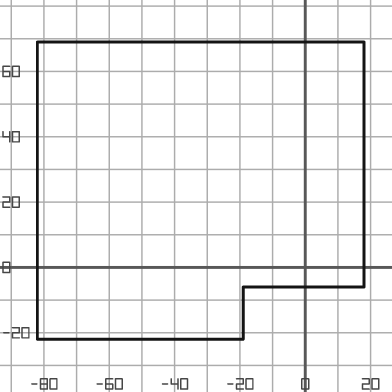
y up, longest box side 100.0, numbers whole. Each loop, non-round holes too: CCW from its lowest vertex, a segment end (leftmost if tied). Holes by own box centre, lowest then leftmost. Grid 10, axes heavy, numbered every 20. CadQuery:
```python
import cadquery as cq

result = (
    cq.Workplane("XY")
    .moveTo(-82.0, -22.0)
    .lineTo(-19.0, -22.0)
    .lineTo(-19.0, -6.0)
    .lineTo(18.0, -6.0)
    .lineTo(18.0, 69.0)
    .lineTo(-82.0, 69.0)
    .close()
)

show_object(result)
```